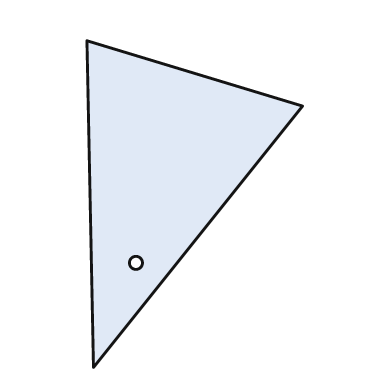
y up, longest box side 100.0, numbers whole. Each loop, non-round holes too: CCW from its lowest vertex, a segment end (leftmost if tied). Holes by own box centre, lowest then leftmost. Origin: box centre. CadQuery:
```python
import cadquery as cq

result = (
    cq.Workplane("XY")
    .moveTo(-31.0, -50.0)
    .lineTo(33.0, 30.0)
    .lineTo(-33.0, 50.0)
    .close()
    .moveTo(-18.0, -18.0)
    .circle(2.0)
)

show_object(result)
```